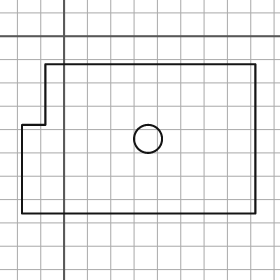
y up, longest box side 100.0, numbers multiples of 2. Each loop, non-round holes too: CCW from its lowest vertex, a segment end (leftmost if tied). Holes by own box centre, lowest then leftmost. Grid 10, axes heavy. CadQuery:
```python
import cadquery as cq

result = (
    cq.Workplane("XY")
    .moveTo(-18.0, -76.0)
    .lineTo(82.0, -76.0)
    .lineTo(82.0, -12.0)
    .lineTo(-8.0, -12.0)
    .lineTo(-8.0, -38.0)
    .lineTo(-18.0, -38.0)
    .close()
    .moveTo(36.0, -44.0)
    .circle(6.0)
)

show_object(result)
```